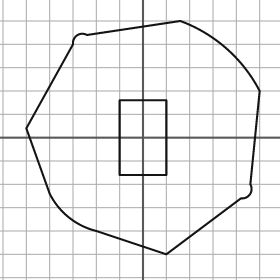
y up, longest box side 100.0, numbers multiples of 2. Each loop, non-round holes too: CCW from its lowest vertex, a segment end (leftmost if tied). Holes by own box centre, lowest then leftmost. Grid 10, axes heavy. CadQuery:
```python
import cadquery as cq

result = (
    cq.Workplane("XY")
    .moveTo(10.0, -50.0)
    .lineTo(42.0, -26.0)
    .threePointArc((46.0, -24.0), (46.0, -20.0))
    .lineTo(50.0, 20.0)
    .threePointArc((36.0, 38.0), (16.0, 50.0))
    .lineTo(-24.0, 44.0)
    .threePointArc((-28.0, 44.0), (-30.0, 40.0))
    .lineTo(-50.0, 4.0)
    .lineTo(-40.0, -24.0)
    .threePointArc((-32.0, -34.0), (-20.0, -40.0))
    .close()
    .moveTo(-10.0, -16.0)
    .lineTo(10.0, -16.0)
    .lineTo(10.0, 16.0)
    .lineTo(-10.0, 16.0)
    .close()
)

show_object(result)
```